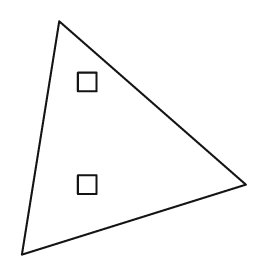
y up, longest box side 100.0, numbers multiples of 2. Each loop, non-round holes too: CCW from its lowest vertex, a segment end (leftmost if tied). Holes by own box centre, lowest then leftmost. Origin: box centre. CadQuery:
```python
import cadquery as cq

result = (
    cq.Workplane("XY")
    .moveTo(-48.0, -50.0)
    .lineTo(48.0, -20.0)
    .lineTo(-32.0, 50.0)
    .close()
    .moveTo(-24.0, -24.0)
    .lineTo(-16.0, -24.0)
    .lineTo(-16.0, -16.0)
    .lineTo(-24.0, -16.0)
    .close()
    .moveTo(-24.0, 20.0)
    .lineTo(-16.0, 20.0)
    .lineTo(-16.0, 28.0)
    .lineTo(-24.0, 28.0)
    .close()
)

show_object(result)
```